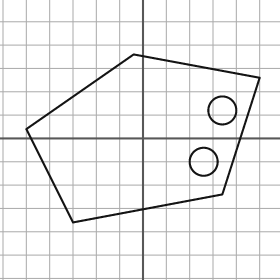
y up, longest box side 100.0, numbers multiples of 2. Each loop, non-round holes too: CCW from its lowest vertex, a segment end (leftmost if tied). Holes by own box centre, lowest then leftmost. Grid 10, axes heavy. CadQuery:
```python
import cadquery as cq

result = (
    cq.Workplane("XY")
    .moveTo(-30.0, -36.0)
    .lineTo(34.0, -24.0)
    .lineTo(50.0, 26.0)
    .lineTo(-4.0, 36.0)
    .lineTo(-50.0, 4.0)
    .close()
    .moveTo(26.0, -10.0)
    .circle(6.0)
    .moveTo(34.0, 12.0)
    .circle(6.0)
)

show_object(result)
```